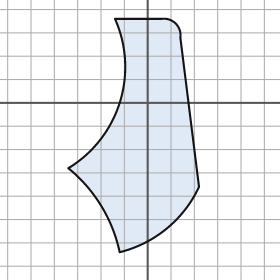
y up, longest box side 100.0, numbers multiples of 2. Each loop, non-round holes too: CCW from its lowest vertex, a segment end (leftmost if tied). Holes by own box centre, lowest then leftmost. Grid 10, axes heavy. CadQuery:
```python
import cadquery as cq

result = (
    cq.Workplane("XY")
    .moveTo(-12.0, -64.0)
    .threePointArc((8.0, -54.0), (22.0, -36.0))
    .lineTo(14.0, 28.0)
    .threePointArc((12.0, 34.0), (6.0, 36.0))
    .lineTo(-14.0, 36.0)
    .threePointArc((-12.0, 0.0), (-34.0, -28.0))
    .threePointArc((-20.0, -44.0), (-12.0, -64.0))
    .close()
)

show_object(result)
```